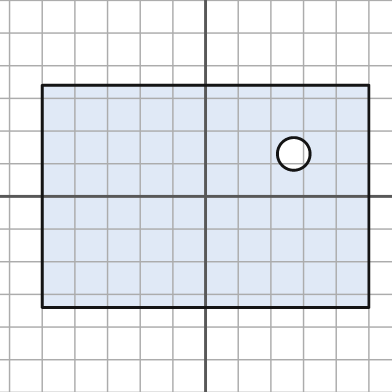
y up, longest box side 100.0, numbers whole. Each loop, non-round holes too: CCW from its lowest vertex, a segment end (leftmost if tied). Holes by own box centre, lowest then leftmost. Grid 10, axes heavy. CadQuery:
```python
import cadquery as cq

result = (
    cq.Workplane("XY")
    .moveTo(-50.0, -34.0)
    .lineTo(50.0, -34.0)
    .lineTo(50.0, 34.0)
    .lineTo(-50.0, 34.0)
    .close()
    .moveTo(27.0, 13.0)
    .circle(5.0)
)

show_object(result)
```